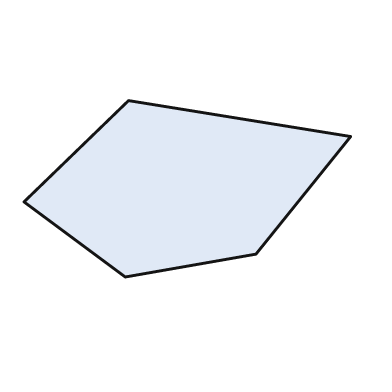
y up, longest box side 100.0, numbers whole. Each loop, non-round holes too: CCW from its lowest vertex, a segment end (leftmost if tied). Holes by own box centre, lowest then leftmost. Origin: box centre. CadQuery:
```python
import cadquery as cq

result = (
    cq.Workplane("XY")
    .moveTo(-19.0, -27.0)
    .lineTo(21.0, -20.0)
    .lineTo(50.0, 16.0)
    .lineTo(-18.0, 27.0)
    .lineTo(-50.0, -4.0)
    .close()
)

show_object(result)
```